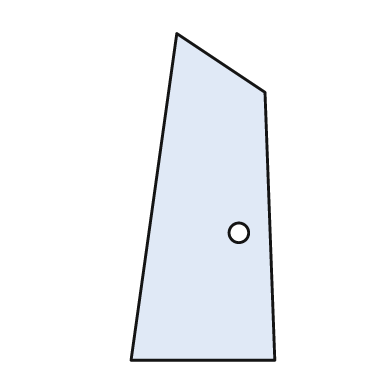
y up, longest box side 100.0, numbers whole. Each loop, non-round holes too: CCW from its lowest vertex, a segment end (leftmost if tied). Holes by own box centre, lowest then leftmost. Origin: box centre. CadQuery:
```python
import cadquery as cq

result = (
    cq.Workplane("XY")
    .moveTo(-22.0, -50.0)
    .lineTo(22.0, -50.0)
    .lineTo(19.0, 32.0)
    .lineTo(-8.0, 50.0)
    .close()
    .moveTo(11.0, -11.0)
    .circle(3.0)
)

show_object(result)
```